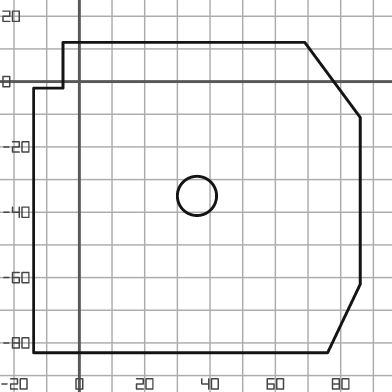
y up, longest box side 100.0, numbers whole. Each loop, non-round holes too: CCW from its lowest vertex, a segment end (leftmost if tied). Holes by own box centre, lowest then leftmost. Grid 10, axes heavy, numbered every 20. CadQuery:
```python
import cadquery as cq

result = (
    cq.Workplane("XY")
    .moveTo(-14.0, -83.0)
    .lineTo(76.0, -83.0)
    .lineTo(86.0, -62.0)
    .lineTo(86.0, -11.0)
    .lineTo(69.0, 12.0)
    .lineTo(-5.0, 12.0)
    .lineTo(-5.0, -2.0)
    .lineTo(-14.0, -2.0)
    .close()
    .moveTo(36.0, -35.0)
    .circle(6.0)
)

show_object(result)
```